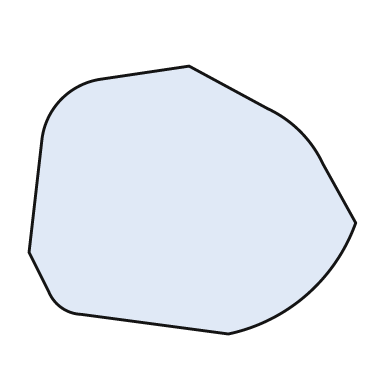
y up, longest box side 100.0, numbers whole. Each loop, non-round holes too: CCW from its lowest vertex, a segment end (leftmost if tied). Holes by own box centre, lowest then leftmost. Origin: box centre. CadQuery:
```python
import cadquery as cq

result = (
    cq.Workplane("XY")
    .moveTo(11.0, -41.0)
    .threePointArc((35.0, -29.0), (50.0, -7.0))
    .lineTo(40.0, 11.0)
    .threePointArc((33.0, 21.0), (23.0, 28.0))
    .lineTo(-1.0, 41.0)
    .lineTo(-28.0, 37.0)
    .threePointArc((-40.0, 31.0), (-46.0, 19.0))
    .lineTo(-50.0, -16.0)
    .lineTo(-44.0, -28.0)
    .threePointArc((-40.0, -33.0), (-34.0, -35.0))
    .close()
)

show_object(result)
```